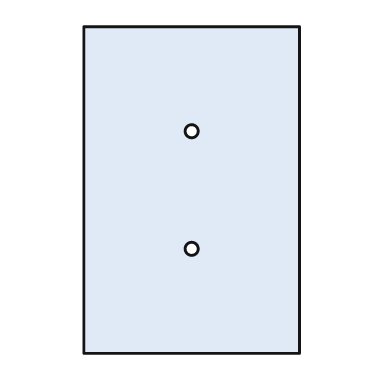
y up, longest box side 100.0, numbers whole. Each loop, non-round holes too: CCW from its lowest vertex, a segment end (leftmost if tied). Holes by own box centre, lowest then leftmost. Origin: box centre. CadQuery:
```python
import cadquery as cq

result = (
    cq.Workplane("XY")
    .moveTo(-33.0, -50.0)
    .lineTo(33.0, -50.0)
    .lineTo(33.0, 50.0)
    .lineTo(-33.0, 50.0)
    .close()
    .moveTo(0.0, -18.0)
    .circle(2.0)
    .moveTo(0.0, 18.0)
    .circle(2.0)
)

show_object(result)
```